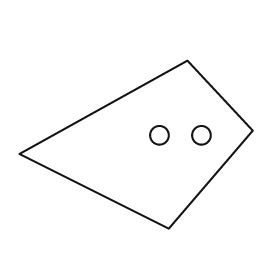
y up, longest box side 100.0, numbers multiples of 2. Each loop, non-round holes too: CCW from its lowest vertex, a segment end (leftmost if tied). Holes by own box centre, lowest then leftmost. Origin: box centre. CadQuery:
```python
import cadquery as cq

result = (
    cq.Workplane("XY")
    .moveTo(14.0, -36.0)
    .lineTo(50.0, 6.0)
    .lineTo(22.0, 36.0)
    .lineTo(-50.0, -4.0)
    .close()
    .moveTo(10.0, 4.0)
    .circle(4.0)
    .moveTo(28.0, 4.0)
    .circle(4.0)
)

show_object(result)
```